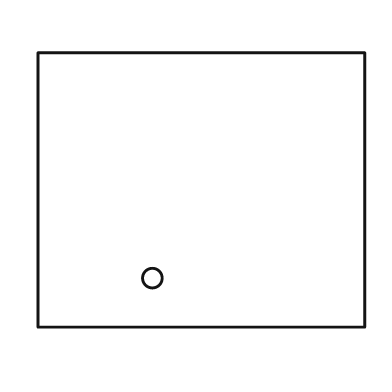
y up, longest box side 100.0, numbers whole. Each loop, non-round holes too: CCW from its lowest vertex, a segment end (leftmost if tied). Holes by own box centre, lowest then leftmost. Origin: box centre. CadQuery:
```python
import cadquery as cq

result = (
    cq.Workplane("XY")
    .moveTo(-50.0, -42.0)
    .lineTo(50.0, -42.0)
    .lineTo(50.0, 42.0)
    .lineTo(-50.0, 42.0)
    .close()
    .moveTo(-15.0, -27.0)
    .circle(3.0)
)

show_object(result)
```